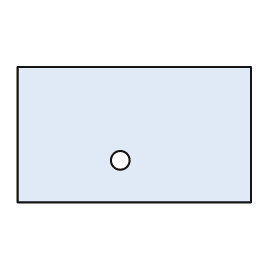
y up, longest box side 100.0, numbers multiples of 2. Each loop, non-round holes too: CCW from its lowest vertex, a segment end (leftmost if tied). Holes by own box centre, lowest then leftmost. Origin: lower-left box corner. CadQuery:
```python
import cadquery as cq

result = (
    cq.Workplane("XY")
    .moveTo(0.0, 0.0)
    .lineTo(100.0, 0.0)
    .lineTo(100.0, 58.0)
    .lineTo(0.0, 58.0)
    .close()
    .moveTo(44.0, 18.0)
    .circle(4.0)
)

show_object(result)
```